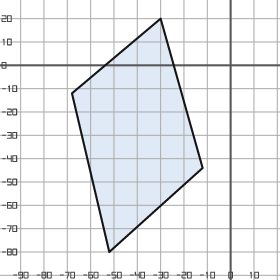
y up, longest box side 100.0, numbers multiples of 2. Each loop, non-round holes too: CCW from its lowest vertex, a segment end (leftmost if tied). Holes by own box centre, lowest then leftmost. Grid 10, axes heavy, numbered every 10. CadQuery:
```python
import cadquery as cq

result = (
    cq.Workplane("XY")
    .moveTo(-52.0, -80.0)
    .lineTo(-12.0, -44.0)
    .lineTo(-30.0, 20.0)
    .lineTo(-68.0, -12.0)
    .close()
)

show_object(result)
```